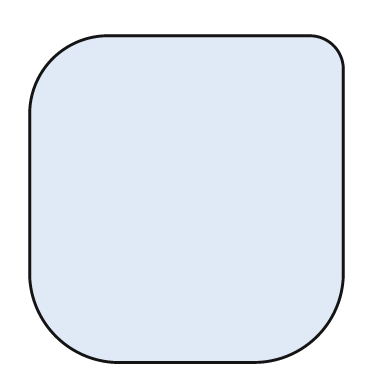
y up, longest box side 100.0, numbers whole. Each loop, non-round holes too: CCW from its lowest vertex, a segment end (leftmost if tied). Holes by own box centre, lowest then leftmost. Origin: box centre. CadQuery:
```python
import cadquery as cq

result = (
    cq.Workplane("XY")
    .moveTo(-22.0, -50.0)
    .lineTo(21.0, -50.0)
    .threePointArc((40.0, -42.0), (48.0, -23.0))
    .lineTo(48.0, 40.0)
    .threePointArc((45.0, 47.0), (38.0, 50.0))
    .lineTo(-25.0, 50.0)
    .threePointArc((-41.0, 43.0), (-48.0, 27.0))
    .lineTo(-48.0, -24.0)
    .threePointArc((-40.0, -42.0), (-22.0, -50.0))
    .close()
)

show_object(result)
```